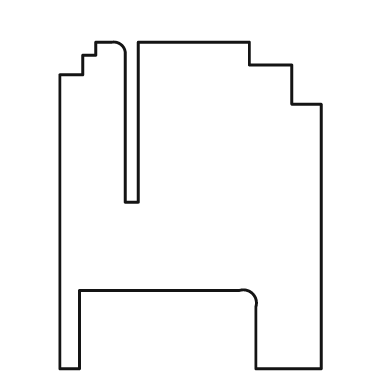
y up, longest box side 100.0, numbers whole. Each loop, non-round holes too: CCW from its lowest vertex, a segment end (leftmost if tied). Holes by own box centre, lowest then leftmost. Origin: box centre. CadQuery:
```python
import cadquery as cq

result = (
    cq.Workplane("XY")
    .moveTo(-40.0, -50.0)
    .lineTo(-34.0, -50.0)
    .lineTo(-34.0, -26.0)
    .lineTo(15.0, -26.0)
    .threePointArc((19.0, -27.0), (20.0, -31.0))
    .lineTo(20.0, -50.0)
    .lineTo(40.0, -50.0)
    .lineTo(40.0, 31.0)
    .lineTo(31.0, 31.0)
    .lineTo(31.0, 43.0)
    .lineTo(18.0, 43.0)
    .lineTo(18.0, 50.0)
    .lineTo(-16.0, 50.0)
    .lineTo(-16.0, 1.0)
    .lineTo(-20.0, 1.0)
    .lineTo(-20.0, 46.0)
    .threePointArc((-21.0, 49.0), (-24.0, 50.0))
    .lineTo(-29.0, 50.0)
    .lineTo(-29.0, 46.0)
    .lineTo(-33.0, 46.0)
    .lineTo(-33.0, 40.0)
    .lineTo(-40.0, 40.0)
    .close()
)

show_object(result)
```